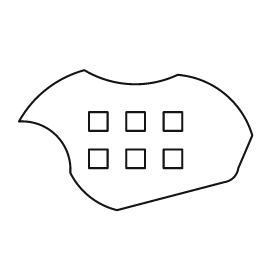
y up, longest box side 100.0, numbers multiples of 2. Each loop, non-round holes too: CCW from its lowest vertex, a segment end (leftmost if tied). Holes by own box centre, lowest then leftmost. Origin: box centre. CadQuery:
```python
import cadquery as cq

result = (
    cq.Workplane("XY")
    .moveTo(-8.0, -30.0)
    .lineTo(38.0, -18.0)
    .threePointArc((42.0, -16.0), (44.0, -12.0))
    .lineTo(50.0, 2.0)
    .threePointArc((38.0, 20.0), (18.0, 28.0))
    .threePointArc((-2.0, 24.0), (-22.0, 30.0))
    .threePointArc((-38.0, 22.0), (-50.0, 8.0))
    .threePointArc((-34.0, 2.0), (-28.0, -14.0))
    .threePointArc((-20.0, -24.0), (-8.0, -30.0))
    .close()
    .moveTo(-20.0, -12.0)
    .lineTo(-12.0, -12.0)
    .lineTo(-12.0, -4.0)
    .lineTo(-20.0, -4.0)
    .close()
    .moveTo(-4.0, -12.0)
    .lineTo(4.0, -12.0)
    .lineTo(4.0, -4.0)
    .lineTo(-4.0, -4.0)
    .close()
    .moveTo(12.0, -12.0)
    .lineTo(20.0, -12.0)
    .lineTo(20.0, -4.0)
    .lineTo(12.0, -4.0)
    .close()
    .moveTo(-20.0, 4.0)
    .lineTo(-12.0, 4.0)
    .lineTo(-12.0, 12.0)
    .lineTo(-20.0, 12.0)
    .close()
    .moveTo(-4.0, 4.0)
    .lineTo(4.0, 4.0)
    .lineTo(4.0, 12.0)
    .lineTo(-4.0, 12.0)
    .close()
    .moveTo(12.0, 4.0)
    .lineTo(20.0, 4.0)
    .lineTo(20.0, 12.0)
    .lineTo(12.0, 12.0)
    .close()
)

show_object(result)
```